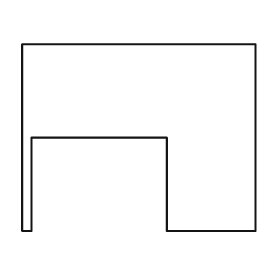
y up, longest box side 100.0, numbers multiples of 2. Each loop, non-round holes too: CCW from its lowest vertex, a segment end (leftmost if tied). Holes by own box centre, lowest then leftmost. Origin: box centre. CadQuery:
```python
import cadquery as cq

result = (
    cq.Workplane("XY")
    .moveTo(-50.0, -40.0)
    .lineTo(-46.0, -40.0)
    .lineTo(-46.0, 0.0)
    .lineTo(12.0, 0.0)
    .lineTo(12.0, -40.0)
    .lineTo(50.0, -40.0)
    .lineTo(50.0, 40.0)
    .lineTo(-50.0, 40.0)
    .close()
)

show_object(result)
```